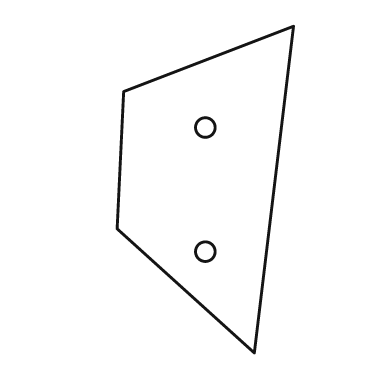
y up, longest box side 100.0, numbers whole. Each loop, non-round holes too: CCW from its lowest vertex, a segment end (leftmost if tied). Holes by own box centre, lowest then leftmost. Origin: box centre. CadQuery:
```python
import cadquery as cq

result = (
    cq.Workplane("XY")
    .moveTo(15.0, -50.0)
    .lineTo(27.0, 50.0)
    .lineTo(-25.0, 30.0)
    .lineTo(-27.0, -12.0)
    .close()
    .moveTo(0.0, -19.0)
    .circle(3.0)
    .moveTo(0.0, 19.0)
    .circle(3.0)
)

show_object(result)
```